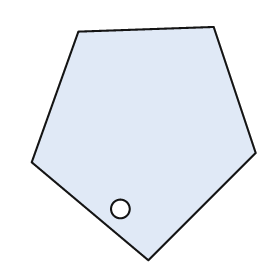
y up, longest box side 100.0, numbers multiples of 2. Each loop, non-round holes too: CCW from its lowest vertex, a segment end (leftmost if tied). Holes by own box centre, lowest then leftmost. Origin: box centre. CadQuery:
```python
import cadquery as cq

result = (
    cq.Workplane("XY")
    .moveTo(2.0, -50.0)
    .lineTo(48.0, -4.0)
    .lineTo(30.0, 50.0)
    .lineTo(-28.0, 48.0)
    .lineTo(-48.0, -8.0)
    .close()
    .moveTo(-10.0, -28.0)
    .circle(4.0)
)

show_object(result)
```